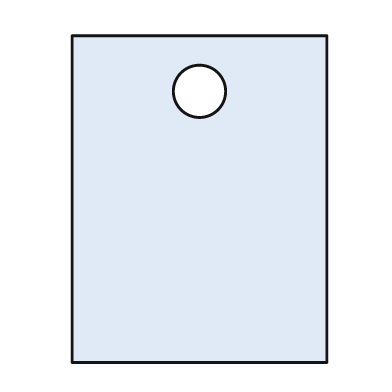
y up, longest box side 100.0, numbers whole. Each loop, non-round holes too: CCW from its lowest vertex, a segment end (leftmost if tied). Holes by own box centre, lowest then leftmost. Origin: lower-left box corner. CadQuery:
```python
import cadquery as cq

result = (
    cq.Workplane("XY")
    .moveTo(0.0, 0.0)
    .lineTo(78.0, 0.0)
    .lineTo(78.0, 100.0)
    .lineTo(0.0, 100.0)
    .close()
    .moveTo(39.0, 83.0)
    .circle(8.0)
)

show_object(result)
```